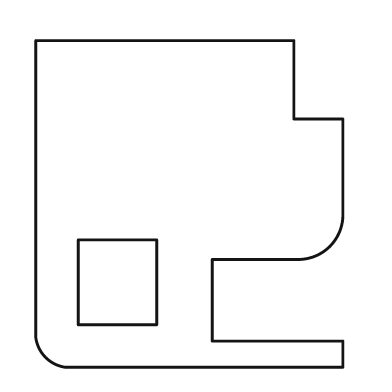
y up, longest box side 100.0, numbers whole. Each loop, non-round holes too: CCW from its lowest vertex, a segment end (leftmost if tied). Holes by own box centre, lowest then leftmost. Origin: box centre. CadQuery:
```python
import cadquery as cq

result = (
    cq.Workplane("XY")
    .moveTo(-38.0, -50.0)
    .lineTo(47.0, -50.0)
    .lineTo(47.0, -42.0)
    .lineTo(7.0, -42.0)
    .lineTo(7.0, -17.0)
    .lineTo(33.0, -17.0)
    .threePointArc((43.0, -13.0), (47.0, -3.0))
    .lineTo(47.0, 26.0)
    .lineTo(32.0, 26.0)
    .lineTo(32.0, 50.0)
    .lineTo(-47.0, 50.0)
    .lineTo(-47.0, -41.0)
    .threePointArc((-44.0, -47.0), (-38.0, -50.0))
    .close()
    .moveTo(-34.0, -37.0)
    .lineTo(-10.0, -37.0)
    .lineTo(-10.0, -11.0)
    .lineTo(-34.0, -11.0)
    .close()
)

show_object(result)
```